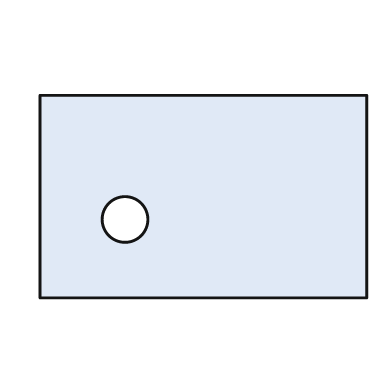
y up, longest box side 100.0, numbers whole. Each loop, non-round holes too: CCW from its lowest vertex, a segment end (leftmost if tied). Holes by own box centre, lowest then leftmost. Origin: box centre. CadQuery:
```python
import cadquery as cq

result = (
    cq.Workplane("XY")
    .moveTo(-50.0, -31.0)
    .lineTo(50.0, -31.0)
    .lineTo(50.0, 31.0)
    .lineTo(-50.0, 31.0)
    .close()
    .moveTo(-24.0, -7.0)
    .circle(7.0)
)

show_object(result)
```